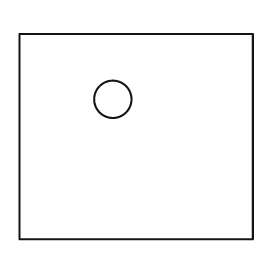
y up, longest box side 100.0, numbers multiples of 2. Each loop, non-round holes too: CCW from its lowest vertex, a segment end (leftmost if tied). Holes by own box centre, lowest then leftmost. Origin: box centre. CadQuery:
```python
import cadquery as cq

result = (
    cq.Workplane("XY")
    .moveTo(-50.0, -44.0)
    .lineTo(50.0, -44.0)
    .lineTo(50.0, 44.0)
    .lineTo(-50.0, 44.0)
    .close()
    .moveTo(-10.0, 16.0)
    .circle(8.0)
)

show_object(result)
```